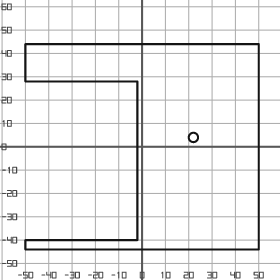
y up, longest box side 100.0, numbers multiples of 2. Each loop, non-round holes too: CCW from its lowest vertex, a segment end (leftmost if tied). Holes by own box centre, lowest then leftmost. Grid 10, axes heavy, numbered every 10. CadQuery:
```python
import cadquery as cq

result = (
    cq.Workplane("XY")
    .moveTo(-50.0, -44.0)
    .lineTo(50.0, -44.0)
    .lineTo(50.0, 44.0)
    .lineTo(-50.0, 44.0)
    .lineTo(-50.0, 28.0)
    .lineTo(-2.0, 28.0)
    .lineTo(-2.0, -40.0)
    .lineTo(-50.0, -40.0)
    .close()
    .moveTo(22.0, 4.0)
    .circle(2.0)
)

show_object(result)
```